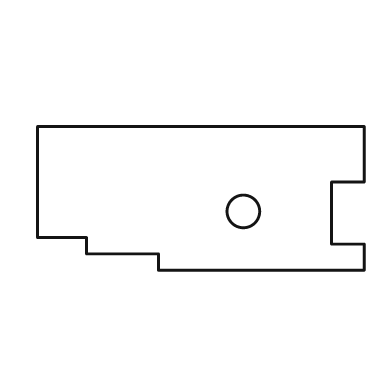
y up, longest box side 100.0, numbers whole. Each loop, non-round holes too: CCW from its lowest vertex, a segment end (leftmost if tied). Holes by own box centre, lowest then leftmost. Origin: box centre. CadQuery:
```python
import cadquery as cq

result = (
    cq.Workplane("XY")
    .moveTo(-13.0, -22.0)
    .lineTo(50.0, -22.0)
    .lineTo(50.0, -14.0)
    .lineTo(40.0, -14.0)
    .lineTo(40.0, 5.0)
    .lineTo(50.0, 5.0)
    .lineTo(50.0, 22.0)
    .lineTo(-50.0, 22.0)
    .lineTo(-50.0, -12.0)
    .lineTo(-35.0, -12.0)
    .lineTo(-35.0, -17.0)
    .lineTo(-13.0, -17.0)
    .close()
    .moveTo(13.0, -4.0)
    .circle(5.0)
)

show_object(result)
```